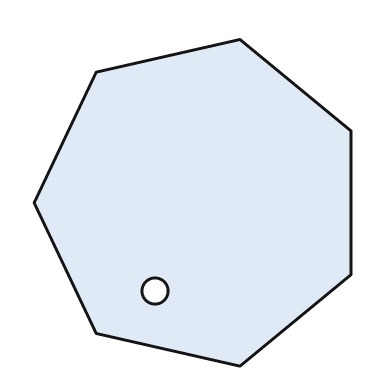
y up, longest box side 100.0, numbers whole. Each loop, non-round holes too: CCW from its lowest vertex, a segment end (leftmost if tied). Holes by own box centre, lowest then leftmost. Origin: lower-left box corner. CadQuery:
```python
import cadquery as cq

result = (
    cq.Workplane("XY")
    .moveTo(63.0, 0.0)
    .lineTo(97.0, 28.0)
    .lineTo(97.0, 72.0)
    .lineTo(63.0, 100.0)
    .lineTo(19.0, 90.0)
    .lineTo(0.0, 50.0)
    .lineTo(19.0, 10.0)
    .close()
    .moveTo(37.0, 23.0)
    .circle(4.0)
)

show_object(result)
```